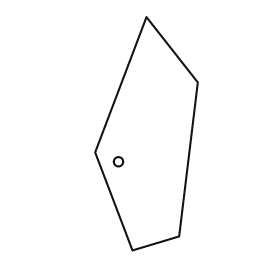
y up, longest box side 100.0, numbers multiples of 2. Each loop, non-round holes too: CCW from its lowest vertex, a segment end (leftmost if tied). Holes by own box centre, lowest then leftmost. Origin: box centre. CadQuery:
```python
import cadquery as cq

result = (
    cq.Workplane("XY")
    .moveTo(-6.0, -50.0)
    .lineTo(14.0, -44.0)
    .lineTo(22.0, 22.0)
    .lineTo(0.0, 50.0)
    .lineTo(-22.0, -8.0)
    .close()
    .moveTo(-12.0, -12.0)
    .circle(2.0)
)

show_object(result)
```